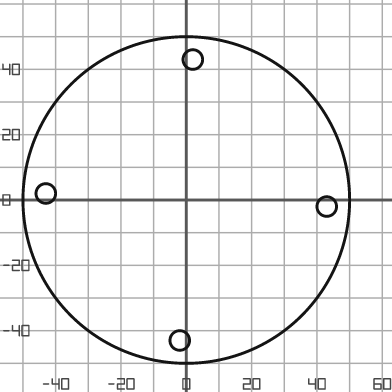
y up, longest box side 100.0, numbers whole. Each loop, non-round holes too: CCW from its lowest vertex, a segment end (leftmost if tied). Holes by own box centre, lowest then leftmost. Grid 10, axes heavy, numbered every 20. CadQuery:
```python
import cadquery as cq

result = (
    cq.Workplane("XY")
    .moveTo(0.0, 0.0)
    .circle(50.0)
    .moveTo(-2.0, -43.0)
    .circle(3.0)
    .moveTo(43.0, -2.0)
    .circle(3.0)
    .moveTo(-43.0, 2.0)
    .circle(3.0)
    .moveTo(2.0, 43.0)
    .circle(3.0)
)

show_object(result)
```